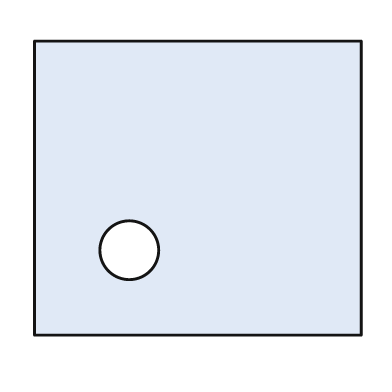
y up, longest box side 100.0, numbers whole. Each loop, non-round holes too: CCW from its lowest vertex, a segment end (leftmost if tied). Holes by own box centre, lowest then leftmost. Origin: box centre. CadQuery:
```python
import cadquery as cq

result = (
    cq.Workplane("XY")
    .moveTo(-50.0, -45.0)
    .lineTo(50.0, -45.0)
    .lineTo(50.0, 45.0)
    .lineTo(-50.0, 45.0)
    .close()
    .moveTo(-21.0, -19.0)
    .circle(9.0)
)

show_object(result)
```